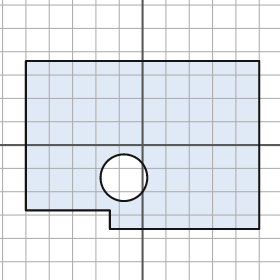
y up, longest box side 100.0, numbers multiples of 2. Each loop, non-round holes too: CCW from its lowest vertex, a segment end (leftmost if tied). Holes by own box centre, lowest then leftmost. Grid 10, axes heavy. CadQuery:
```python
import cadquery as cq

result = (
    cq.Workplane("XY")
    .moveTo(-14.0, -36.0)
    .lineTo(50.0, -36.0)
    .lineTo(50.0, 36.0)
    .lineTo(-50.0, 36.0)
    .lineTo(-50.0, -28.0)
    .lineTo(-14.0, -28.0)
    .close()
    .moveTo(-8.0, -14.0)
    .circle(10.0)
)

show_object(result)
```